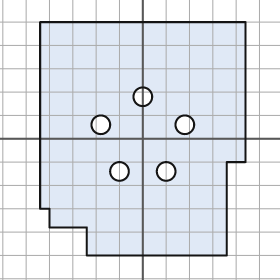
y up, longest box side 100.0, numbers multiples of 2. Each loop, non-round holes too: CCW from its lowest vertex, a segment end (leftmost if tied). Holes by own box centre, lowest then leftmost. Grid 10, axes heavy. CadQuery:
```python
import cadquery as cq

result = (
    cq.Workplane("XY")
    .moveTo(-24.0, -50.0)
    .lineTo(36.0, -50.0)
    .lineTo(36.0, -10.0)
    .lineTo(44.0, -10.0)
    .lineTo(44.0, 50.0)
    .lineTo(-44.0, 50.0)
    .lineTo(-44.0, -30.0)
    .lineTo(-40.0, -30.0)
    .lineTo(-40.0, -38.0)
    .lineTo(-24.0, -38.0)
    .close()
    .moveTo(-10.0, -14.0)
    .circle(4.0)
    .moveTo(10.0, -14.0)
    .circle(4.0)
    .moveTo(-18.0, 6.0)
    .circle(4.0)
    .moveTo(18.0, 6.0)
    .circle(4.0)
    .moveTo(0.0, 18.0)
    .circle(4.0)
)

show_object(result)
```